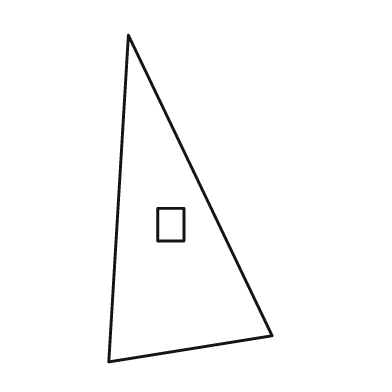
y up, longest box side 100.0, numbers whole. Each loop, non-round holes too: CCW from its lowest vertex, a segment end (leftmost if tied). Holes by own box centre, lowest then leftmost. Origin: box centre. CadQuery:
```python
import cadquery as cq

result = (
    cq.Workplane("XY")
    .moveTo(-25.0, -50.0)
    .lineTo(25.0, -42.0)
    .lineTo(-19.0, 50.0)
    .close()
    .moveTo(-10.0, -13.0)
    .lineTo(-2.0, -13.0)
    .lineTo(-2.0, -3.0)
    .lineTo(-10.0, -3.0)
    .close()
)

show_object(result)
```